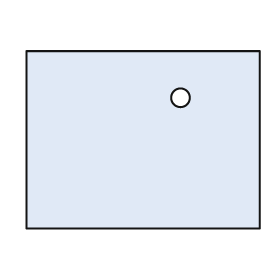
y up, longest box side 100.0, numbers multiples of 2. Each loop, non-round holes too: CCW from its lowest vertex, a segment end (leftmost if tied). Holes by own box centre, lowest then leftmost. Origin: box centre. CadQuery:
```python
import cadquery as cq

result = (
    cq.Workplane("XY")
    .moveTo(-50.0, -38.0)
    .lineTo(50.0, -38.0)
    .lineTo(50.0, 38.0)
    .lineTo(-50.0, 38.0)
    .close()
    .moveTo(16.0, 18.0)
    .circle(4.0)
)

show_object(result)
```